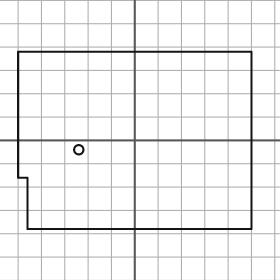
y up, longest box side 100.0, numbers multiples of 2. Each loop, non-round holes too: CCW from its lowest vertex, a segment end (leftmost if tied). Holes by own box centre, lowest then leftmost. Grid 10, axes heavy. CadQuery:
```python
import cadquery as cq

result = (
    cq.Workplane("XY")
    .moveTo(-46.0, -38.0)
    .lineTo(50.0, -38.0)
    .lineTo(50.0, 38.0)
    .lineTo(-50.0, 38.0)
    .lineTo(-50.0, -16.0)
    .lineTo(-46.0, -16.0)
    .close()
    .moveTo(-24.0, -4.0)
    .circle(2.0)
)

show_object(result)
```